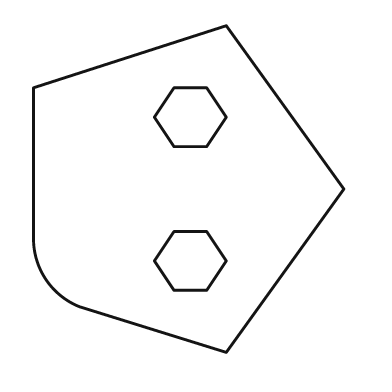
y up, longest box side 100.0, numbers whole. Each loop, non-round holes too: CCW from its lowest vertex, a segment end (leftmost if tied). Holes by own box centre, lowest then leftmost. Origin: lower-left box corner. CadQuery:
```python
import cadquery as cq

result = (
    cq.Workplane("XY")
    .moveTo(59.0, 0.0)
    .lineTo(95.0, 50.0)
    .lineTo(59.0, 100.0)
    .lineTo(0.0, 81.0)
    .lineTo(0.0, 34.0)
    .threePointArc((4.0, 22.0), (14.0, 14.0))
    .close()
    .moveTo(43.0, 19.0)
    .lineTo(53.0, 19.0)
    .lineTo(59.0, 28.0)
    .lineTo(53.0, 37.0)
    .lineTo(43.0, 37.0)
    .lineTo(37.0, 28.0)
    .close()
    .moveTo(43.0, 63.0)
    .lineTo(53.0, 63.0)
    .lineTo(59.0, 72.0)
    .lineTo(53.0, 81.0)
    .lineTo(43.0, 81.0)
    .lineTo(37.0, 72.0)
    .close()
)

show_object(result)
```